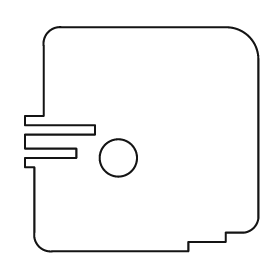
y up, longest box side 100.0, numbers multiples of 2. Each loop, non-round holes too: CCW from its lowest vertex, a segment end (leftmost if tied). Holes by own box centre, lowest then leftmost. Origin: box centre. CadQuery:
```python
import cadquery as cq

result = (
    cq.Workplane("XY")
    .moveTo(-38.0, -48.0)
    .lineTo(20.0, -48.0)
    .lineTo(20.0, -44.0)
    .lineTo(36.0, -44.0)
    .lineTo(36.0, -40.0)
    .lineTo(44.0, -40.0)
    .threePointArc((48.0, -38.0), (50.0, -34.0))
    .lineTo(50.0, 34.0)
    .threePointArc((46.0, 44.0), (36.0, 48.0))
    .lineTo(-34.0, 48.0)
    .threePointArc((-40.0, 46.0), (-42.0, 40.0))
    .lineTo(-42.0, 10.0)
    .lineTo(-50.0, 10.0)
    .lineTo(-50.0, 6.0)
    .lineTo(-20.0, 6.0)
    .lineTo(-20.0, 2.0)
    .lineTo(-50.0, 2.0)
    .lineTo(-50.0, -4.0)
    .lineTo(-28.0, -4.0)
    .lineTo(-28.0, -8.0)
    .lineTo(-50.0, -8.0)
    .lineTo(-50.0, -12.0)
    .lineTo(-46.0, -12.0)
    .lineTo(-46.0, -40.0)
    .threePointArc((-44.0, -46.0), (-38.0, -48.0))
    .close()
    .moveTo(-10.0, -8.0)
    .circle(8.0)
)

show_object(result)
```